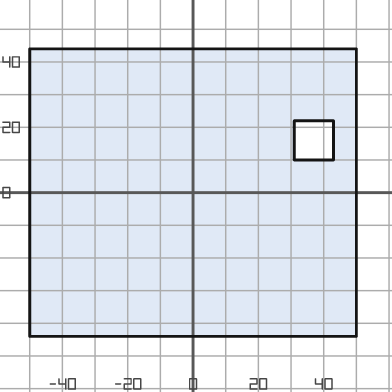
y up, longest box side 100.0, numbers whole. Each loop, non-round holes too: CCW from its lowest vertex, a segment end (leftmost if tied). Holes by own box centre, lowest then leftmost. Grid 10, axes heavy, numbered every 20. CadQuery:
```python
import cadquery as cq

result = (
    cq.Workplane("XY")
    .moveTo(-50.0, -44.0)
    .lineTo(50.0, -44.0)
    .lineTo(50.0, 44.0)
    .lineTo(-50.0, 44.0)
    .close()
    .moveTo(31.0, 10.0)
    .lineTo(43.0, 10.0)
    .lineTo(43.0, 22.0)
    .lineTo(31.0, 22.0)
    .close()
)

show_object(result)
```